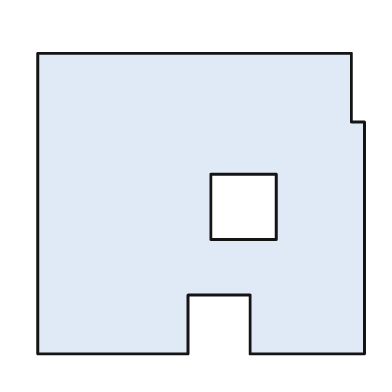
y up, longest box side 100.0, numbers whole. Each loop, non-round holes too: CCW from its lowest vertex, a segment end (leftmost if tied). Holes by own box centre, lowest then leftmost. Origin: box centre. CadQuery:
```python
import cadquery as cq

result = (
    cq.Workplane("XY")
    .moveTo(-50.0, -46.0)
    .lineTo(-4.0, -46.0)
    .lineTo(-4.0, -28.0)
    .lineTo(15.0, -28.0)
    .lineTo(15.0, -46.0)
    .lineTo(50.0, -46.0)
    .lineTo(50.0, 25.0)
    .lineTo(46.0, 25.0)
    .lineTo(46.0, 46.0)
    .lineTo(-50.0, 46.0)
    .close()
    .moveTo(3.0, -11.0)
    .lineTo(23.0, -11.0)
    .lineTo(23.0, 9.0)
    .lineTo(3.0, 9.0)
    .close()
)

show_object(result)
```